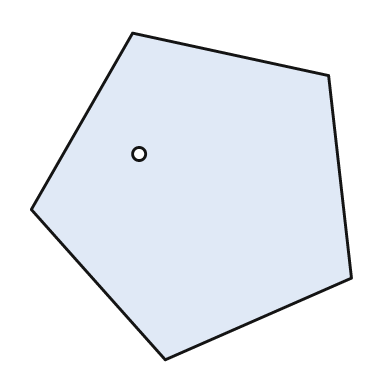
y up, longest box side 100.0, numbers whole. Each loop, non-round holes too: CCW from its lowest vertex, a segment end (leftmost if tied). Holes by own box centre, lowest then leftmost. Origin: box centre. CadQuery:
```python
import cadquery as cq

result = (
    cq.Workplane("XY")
    .moveTo(-8.0, -50.0)
    .lineTo(49.0, -25.0)
    .lineTo(42.0, 37.0)
    .lineTo(-18.0, 50.0)
    .lineTo(-49.0, -4.0)
    .close()
    .moveTo(-16.0, 13.0)
    .circle(2.0)
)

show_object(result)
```